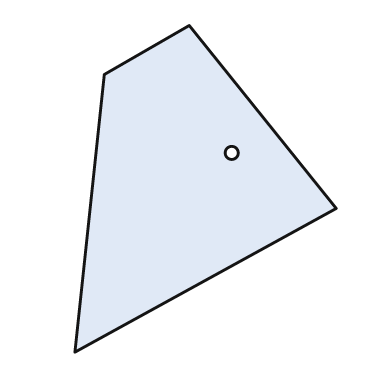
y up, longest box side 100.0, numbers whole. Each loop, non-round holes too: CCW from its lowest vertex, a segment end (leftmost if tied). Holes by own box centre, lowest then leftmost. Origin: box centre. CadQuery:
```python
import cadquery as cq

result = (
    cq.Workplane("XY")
    .moveTo(-40.0, -50.0)
    .lineTo(40.0, -6.0)
    .lineTo(-5.0, 50.0)
    .lineTo(-31.0, 35.0)
    .close()
    .moveTo(8.0, 11.0)
    .circle(2.0)
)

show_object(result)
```